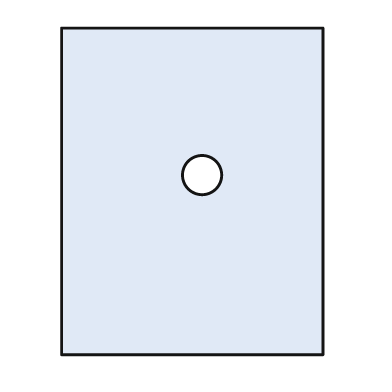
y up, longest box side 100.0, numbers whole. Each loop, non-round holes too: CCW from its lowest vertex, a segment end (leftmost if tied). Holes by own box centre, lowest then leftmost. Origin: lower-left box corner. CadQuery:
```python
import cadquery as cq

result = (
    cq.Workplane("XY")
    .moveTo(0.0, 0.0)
    .lineTo(80.0, 0.0)
    .lineTo(80.0, 100.0)
    .lineTo(0.0, 100.0)
    .close()
    .moveTo(43.0, 55.0)
    .circle(6.0)
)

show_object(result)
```